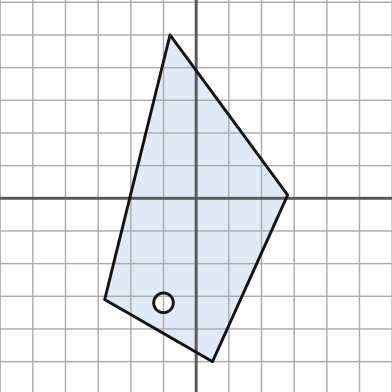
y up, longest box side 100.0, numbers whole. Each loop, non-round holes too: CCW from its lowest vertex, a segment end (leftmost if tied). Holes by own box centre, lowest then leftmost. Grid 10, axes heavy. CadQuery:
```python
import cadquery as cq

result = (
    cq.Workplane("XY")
    .moveTo(5.0, -50.0)
    .lineTo(28.0, 1.0)
    .lineTo(-8.0, 50.0)
    .lineTo(-28.0, -31.0)
    .close()
    .moveTo(-10.0, -32.0)
    .circle(3.0)
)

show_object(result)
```